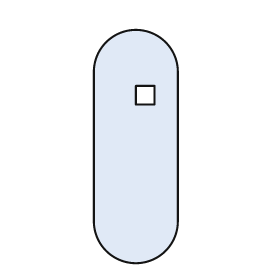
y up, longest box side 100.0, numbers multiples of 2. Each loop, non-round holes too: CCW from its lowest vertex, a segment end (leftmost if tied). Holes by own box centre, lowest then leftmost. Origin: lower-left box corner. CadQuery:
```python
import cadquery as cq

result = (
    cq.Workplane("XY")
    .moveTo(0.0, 18.0)
    .threePointArc((18.0, 0.0), (36.0, 18.0))
    .lineTo(36.0, 82.0)
    .threePointArc((18.0, 100.0), (0.0, 82.0))
    .close()
    .moveTo(18.0, 68.0)
    .lineTo(26.0, 68.0)
    .lineTo(26.0, 76.0)
    .lineTo(18.0, 76.0)
    .close()
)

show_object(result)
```